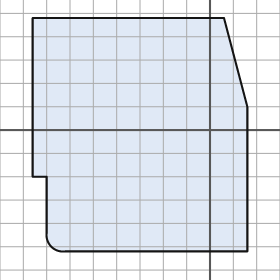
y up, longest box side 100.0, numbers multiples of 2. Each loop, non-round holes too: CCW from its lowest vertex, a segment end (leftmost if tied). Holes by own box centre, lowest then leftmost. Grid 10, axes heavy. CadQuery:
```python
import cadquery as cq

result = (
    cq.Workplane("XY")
    .moveTo(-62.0, -52.0)
    .lineTo(16.0, -52.0)
    .lineTo(16.0, 10.0)
    .lineTo(6.0, 48.0)
    .lineTo(-76.0, 48.0)
    .lineTo(-76.0, -20.0)
    .lineTo(-70.0, -20.0)
    .lineTo(-70.0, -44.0)
    .threePointArc((-68.0, -50.0), (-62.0, -52.0))
    .close()
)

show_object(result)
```